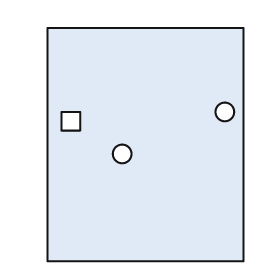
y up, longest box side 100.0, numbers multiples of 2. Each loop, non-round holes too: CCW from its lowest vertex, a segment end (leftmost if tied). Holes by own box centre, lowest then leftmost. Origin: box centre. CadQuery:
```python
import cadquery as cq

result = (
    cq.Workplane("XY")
    .moveTo(-42.0, -50.0)
    .lineTo(42.0, -50.0)
    .lineTo(42.0, 50.0)
    .lineTo(-42.0, 50.0)
    .close()
    .moveTo(-10.0, -4.0)
    .circle(4.0)
    .moveTo(-36.0, 6.0)
    .lineTo(-28.0, 6.0)
    .lineTo(-28.0, 14.0)
    .lineTo(-36.0, 14.0)
    .close()
    .moveTo(34.0, 14.0)
    .circle(4.0)
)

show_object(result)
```